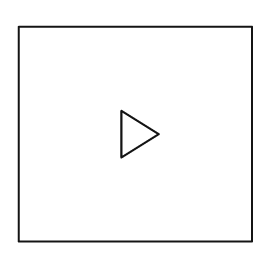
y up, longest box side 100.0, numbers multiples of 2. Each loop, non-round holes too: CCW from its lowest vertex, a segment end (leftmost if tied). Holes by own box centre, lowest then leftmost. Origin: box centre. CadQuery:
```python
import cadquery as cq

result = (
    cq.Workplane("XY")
    .moveTo(-50.0, -46.0)
    .lineTo(50.0, -46.0)
    .lineTo(50.0, 46.0)
    .lineTo(-50.0, 46.0)
    .close()
    .moveTo(-6.0, -10.0)
    .lineTo(10.0, 0.0)
    .lineTo(-6.0, 10.0)
    .close()
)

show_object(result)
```